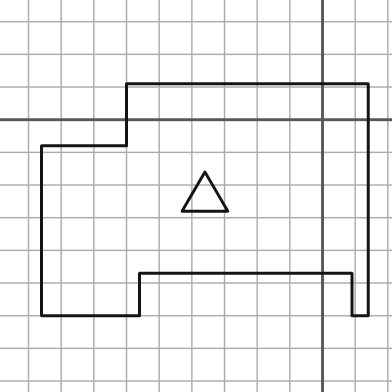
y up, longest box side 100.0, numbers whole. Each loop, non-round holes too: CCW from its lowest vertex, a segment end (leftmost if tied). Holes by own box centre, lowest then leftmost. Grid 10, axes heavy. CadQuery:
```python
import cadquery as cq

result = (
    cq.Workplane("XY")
    .moveTo(-86.0, -60.0)
    .lineTo(-56.0, -60.0)
    .lineTo(-56.0, -47.0)
    .lineTo(9.0, -47.0)
    .lineTo(9.0, -60.0)
    .lineTo(14.0, -60.0)
    .lineTo(14.0, 11.0)
    .lineTo(-60.0, 11.0)
    .lineTo(-60.0, -8.0)
    .lineTo(-86.0, -8.0)
    .close()
    .moveTo(-43.0, -28.0)
    .lineTo(-29.0, -28.0)
    .lineTo(-36.0, -16.0)
    .close()
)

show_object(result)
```